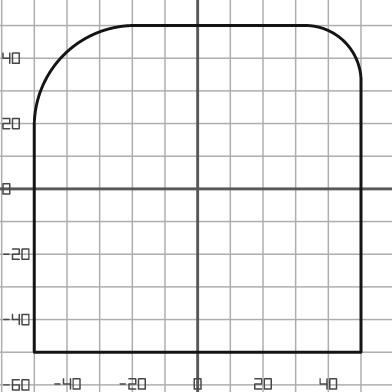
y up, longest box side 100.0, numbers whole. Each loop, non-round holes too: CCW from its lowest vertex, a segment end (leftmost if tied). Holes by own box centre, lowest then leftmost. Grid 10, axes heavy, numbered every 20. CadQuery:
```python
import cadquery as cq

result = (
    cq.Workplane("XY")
    .moveTo(-50.0, -50.0)
    .lineTo(50.0, -50.0)
    .lineTo(50.0, 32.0)
    .threePointArc((45.0, 45.0), (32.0, 50.0))
    .lineTo(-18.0, 50.0)
    .threePointArc((-41.0, 41.0), (-50.0, 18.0))
    .close()
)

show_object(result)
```